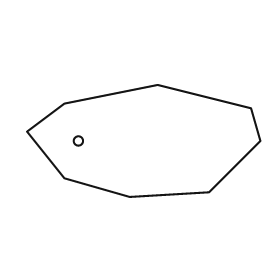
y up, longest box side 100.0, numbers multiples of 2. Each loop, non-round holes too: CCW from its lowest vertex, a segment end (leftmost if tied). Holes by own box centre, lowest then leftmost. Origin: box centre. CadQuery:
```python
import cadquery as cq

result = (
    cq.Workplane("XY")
    .moveTo(-6.0, -24.0)
    .lineTo(28.0, -22.0)
    .lineTo(50.0, 0.0)
    .lineTo(46.0, 14.0)
    .lineTo(6.0, 24.0)
    .lineTo(-34.0, 16.0)
    .lineTo(-50.0, 4.0)
    .lineTo(-34.0, -16.0)
    .close()
    .moveTo(-28.0, 0.0)
    .circle(2.0)
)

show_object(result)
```